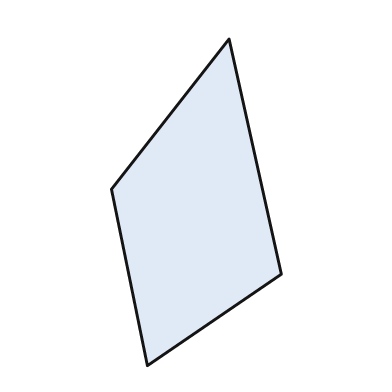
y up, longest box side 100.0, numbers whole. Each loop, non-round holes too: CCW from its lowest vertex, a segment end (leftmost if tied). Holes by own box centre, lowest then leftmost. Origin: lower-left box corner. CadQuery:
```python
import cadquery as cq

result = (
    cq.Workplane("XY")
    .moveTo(11.0, 0.0)
    .lineTo(52.0, 28.0)
    .lineTo(36.0, 100.0)
    .lineTo(0.0, 54.0)
    .close()
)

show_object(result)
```